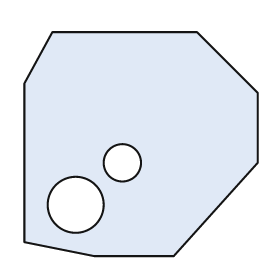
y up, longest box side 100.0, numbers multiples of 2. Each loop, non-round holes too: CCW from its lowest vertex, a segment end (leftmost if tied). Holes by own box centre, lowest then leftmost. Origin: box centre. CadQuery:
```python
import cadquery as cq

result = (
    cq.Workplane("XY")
    .moveTo(-20.0, -48.0)
    .lineTo(14.0, -48.0)
    .lineTo(50.0, -8.0)
    .lineTo(50.0, 22.0)
    .lineTo(24.0, 48.0)
    .lineTo(-38.0, 48.0)
    .lineTo(-50.0, 26.0)
    .lineTo(-50.0, -42.0)
    .close()
    .moveTo(-28.0, -26.0)
    .circle(12.0)
    .moveTo(-8.0, -8.0)
    .circle(8.0)
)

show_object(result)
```